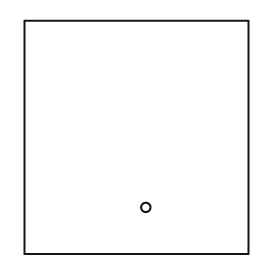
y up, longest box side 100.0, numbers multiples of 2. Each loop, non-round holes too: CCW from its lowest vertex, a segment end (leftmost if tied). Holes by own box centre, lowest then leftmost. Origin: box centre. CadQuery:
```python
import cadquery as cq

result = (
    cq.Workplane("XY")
    .moveTo(-48.0, -50.0)
    .lineTo(48.0, -50.0)
    .lineTo(48.0, 50.0)
    .lineTo(-48.0, 50.0)
    .close()
    .moveTo(4.0, -30.0)
    .circle(2.0)
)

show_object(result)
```